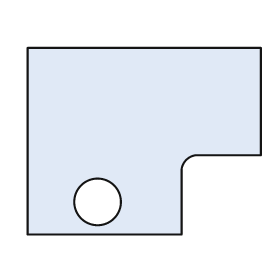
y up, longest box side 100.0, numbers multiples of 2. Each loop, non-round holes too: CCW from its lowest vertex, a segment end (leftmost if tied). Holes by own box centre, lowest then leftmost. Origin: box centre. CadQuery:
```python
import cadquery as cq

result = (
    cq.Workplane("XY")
    .moveTo(-50.0, -40.0)
    .lineTo(16.0, -40.0)
    .lineTo(16.0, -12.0)
    .threePointArc((18.0, -8.0), (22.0, -6.0))
    .lineTo(50.0, -6.0)
    .lineTo(50.0, 40.0)
    .lineTo(-50.0, 40.0)
    .close()
    .moveTo(-20.0, -26.0)
    .circle(10.0)
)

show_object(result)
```